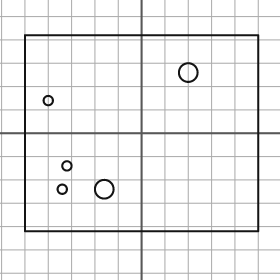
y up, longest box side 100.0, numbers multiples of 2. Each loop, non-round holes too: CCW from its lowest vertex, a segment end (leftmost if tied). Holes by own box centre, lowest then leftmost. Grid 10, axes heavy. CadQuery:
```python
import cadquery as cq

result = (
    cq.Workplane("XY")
    .moveTo(-50.0, -42.0)
    .lineTo(50.0, -42.0)
    .lineTo(50.0, 42.0)
    .lineTo(-50.0, 42.0)
    .close()
    .moveTo(-34.0, -24.0)
    .circle(2.0)
    .moveTo(-16.0, -24.0)
    .circle(4.0)
    .moveTo(-32.0, -14.0)
    .circle(2.0)
    .moveTo(-40.0, 14.0)
    .circle(2.0)
    .moveTo(20.0, 26.0)
    .circle(4.0)
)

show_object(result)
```